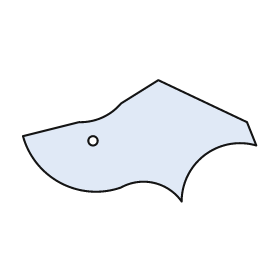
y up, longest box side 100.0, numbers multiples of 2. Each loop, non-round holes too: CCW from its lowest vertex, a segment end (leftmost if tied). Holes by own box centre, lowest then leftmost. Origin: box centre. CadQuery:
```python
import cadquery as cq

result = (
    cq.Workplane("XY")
    .moveTo(18.0, -26.0)
    .threePointArc((28.0, -6.0), (50.0, -2.0))
    .lineTo(46.0, 8.0)
    .lineTo(8.0, 26.0)
    .lineTo(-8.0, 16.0)
    .threePointArc((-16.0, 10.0), (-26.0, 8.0))
    .lineTo(-50.0, 2.0)
    .threePointArc((-34.0, -18.0), (-8.0, -20.0))
    .threePointArc((6.0, -18.0), (18.0, -26.0))
    .close()
    .moveTo(-20.0, 0.0)
    .circle(2.0)
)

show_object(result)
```